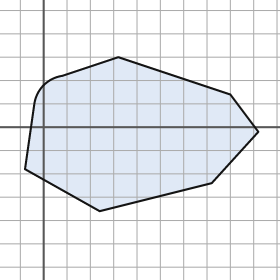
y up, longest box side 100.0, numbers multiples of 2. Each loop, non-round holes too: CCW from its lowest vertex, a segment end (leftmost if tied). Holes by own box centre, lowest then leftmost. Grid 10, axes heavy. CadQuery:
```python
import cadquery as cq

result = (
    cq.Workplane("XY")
    .moveTo(24.0, -36.0)
    .lineTo(72.0, -24.0)
    .lineTo(92.0, -2.0)
    .lineTo(80.0, 14.0)
    .lineTo(32.0, 30.0)
    .lineTo(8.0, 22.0)
    .threePointArc((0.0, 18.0), (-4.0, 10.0))
    .lineTo(-8.0, -18.0)
    .close()
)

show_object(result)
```